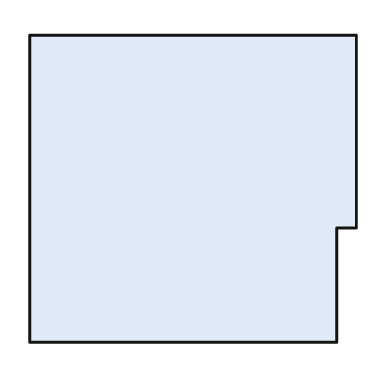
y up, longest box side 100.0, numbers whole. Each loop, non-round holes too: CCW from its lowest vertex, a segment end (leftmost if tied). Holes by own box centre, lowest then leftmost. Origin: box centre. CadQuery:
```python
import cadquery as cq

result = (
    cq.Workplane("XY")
    .moveTo(-50.0, -47.0)
    .lineTo(44.0, -47.0)
    .lineTo(44.0, -12.0)
    .lineTo(50.0, -12.0)
    .lineTo(50.0, 47.0)
    .lineTo(-50.0, 47.0)
    .close()
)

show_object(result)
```